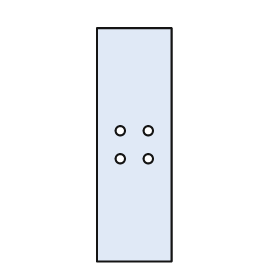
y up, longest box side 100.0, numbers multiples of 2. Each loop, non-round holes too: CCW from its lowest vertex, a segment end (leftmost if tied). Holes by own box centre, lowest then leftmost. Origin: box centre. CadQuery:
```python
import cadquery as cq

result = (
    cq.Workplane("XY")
    .moveTo(-16.0, -50.0)
    .lineTo(16.0, -50.0)
    .lineTo(16.0, 50.0)
    .lineTo(-16.0, 50.0)
    .close()
    .moveTo(-6.0, -6.0)
    .circle(2.0)
    .moveTo(6.0, -6.0)
    .circle(2.0)
    .moveTo(-6.0, 6.0)
    .circle(2.0)
    .moveTo(6.0, 6.0)
    .circle(2.0)
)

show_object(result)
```